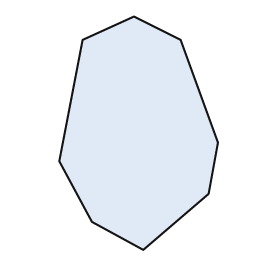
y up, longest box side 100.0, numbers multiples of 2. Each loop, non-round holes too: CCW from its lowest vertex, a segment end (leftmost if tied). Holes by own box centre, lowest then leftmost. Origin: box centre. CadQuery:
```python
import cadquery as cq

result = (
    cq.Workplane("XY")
    .moveTo(2.0, -50.0)
    .lineTo(30.0, -26.0)
    .lineTo(34.0, -4.0)
    .lineTo(18.0, 40.0)
    .lineTo(-2.0, 50.0)
    .lineTo(-24.0, 40.0)
    .lineTo(-34.0, -12.0)
    .lineTo(-20.0, -38.0)
    .close()
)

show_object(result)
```